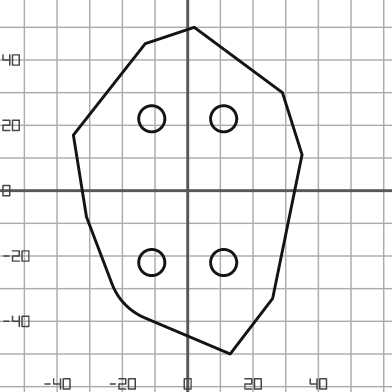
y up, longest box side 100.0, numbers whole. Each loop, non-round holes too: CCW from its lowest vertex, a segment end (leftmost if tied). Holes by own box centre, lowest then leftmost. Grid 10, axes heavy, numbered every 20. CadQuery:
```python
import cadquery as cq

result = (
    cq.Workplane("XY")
    .moveTo(13.0, -50.0)
    .lineTo(26.0, -33.0)
    .lineTo(35.0, 11.0)
    .lineTo(29.0, 30.0)
    .lineTo(2.0, 50.0)
    .lineTo(-13.0, 45.0)
    .lineTo(-35.0, 17.0)
    .lineTo(-31.0, -8.0)
    .lineTo(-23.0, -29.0)
    .threePointArc((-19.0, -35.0), (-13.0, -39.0))
    .close()
    .moveTo(-11.0, -22.0)
    .circle(4.0)
    .moveTo(11.0, -22.0)
    .circle(4.0)
    .moveTo(-11.0, 22.0)
    .circle(4.0)
    .moveTo(11.0, 22.0)
    .circle(4.0)
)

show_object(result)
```